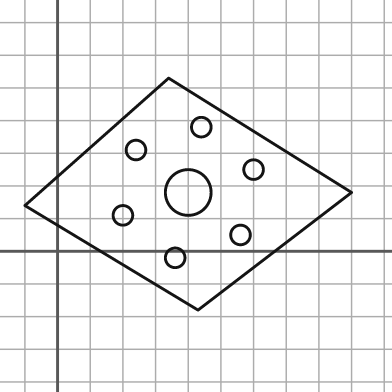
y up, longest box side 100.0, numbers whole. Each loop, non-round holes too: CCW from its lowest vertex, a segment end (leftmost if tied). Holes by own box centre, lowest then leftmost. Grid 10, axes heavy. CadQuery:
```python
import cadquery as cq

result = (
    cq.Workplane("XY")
    .moveTo(43.0, -18.0)
    .lineTo(90.0, 18.0)
    .lineTo(34.0, 53.0)
    .lineTo(-10.0, 14.0)
    .close()
    .moveTo(36.0, -2.0)
    .circle(3.0)
    .moveTo(56.0, 5.0)
    .circle(3.0)
    .moveTo(20.0, 11.0)
    .circle(3.0)
    .moveTo(40.0, 18.0)
    .circle(7.0)
    .moveTo(60.0, 25.0)
    .circle(3.0)
    .moveTo(24.0, 31.0)
    .circle(3.0)
    .moveTo(44.0, 38.0)
    .circle(3.0)
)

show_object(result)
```